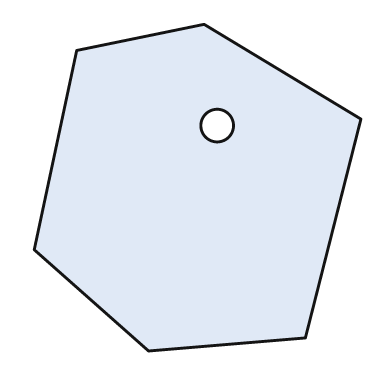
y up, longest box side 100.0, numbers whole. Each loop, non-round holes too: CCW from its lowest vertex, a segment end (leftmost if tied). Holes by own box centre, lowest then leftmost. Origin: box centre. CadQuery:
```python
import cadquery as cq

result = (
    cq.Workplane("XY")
    .moveTo(-15.0, -50.0)
    .lineTo(33.0, -46.0)
    .lineTo(50.0, 21.0)
    .lineTo(2.0, 50.0)
    .lineTo(-37.0, 42.0)
    .lineTo(-50.0, -19.0)
    .close()
    .moveTo(6.0, 19.0)
    .circle(5.0)
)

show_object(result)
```